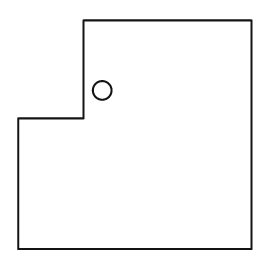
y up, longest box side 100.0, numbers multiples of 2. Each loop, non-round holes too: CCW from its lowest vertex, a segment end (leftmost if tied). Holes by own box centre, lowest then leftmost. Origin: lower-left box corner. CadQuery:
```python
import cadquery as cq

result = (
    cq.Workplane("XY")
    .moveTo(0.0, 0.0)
    .lineTo(100.0, 0.0)
    .lineTo(100.0, 98.0)
    .lineTo(28.0, 98.0)
    .lineTo(28.0, 56.0)
    .lineTo(0.0, 56.0)
    .close()
    .moveTo(36.0, 68.0)
    .circle(4.0)
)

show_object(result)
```